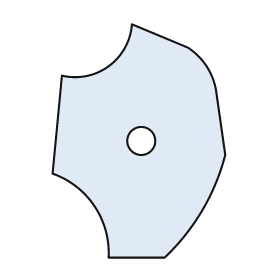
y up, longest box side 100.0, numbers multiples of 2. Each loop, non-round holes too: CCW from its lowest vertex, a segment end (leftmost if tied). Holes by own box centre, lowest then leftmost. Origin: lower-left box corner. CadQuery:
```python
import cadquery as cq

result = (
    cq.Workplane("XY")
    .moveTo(24.0, 0.0)
    .lineTo(48.0, 0.0)
    .threePointArc((64.0, 20.0), (74.0, 44.0))
    .lineTo(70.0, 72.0)
    .threePointArc((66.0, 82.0), (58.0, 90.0))
    .lineTo(34.0, 100.0)
    .threePointArc((24.0, 82.0), (4.0, 78.0))
    .lineTo(0.0, 36.0)
    .threePointArc((18.0, 22.0), (24.0, 0.0))
    .close()
    .moveTo(38.0, 50.0)
    .circle(6.0)
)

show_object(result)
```